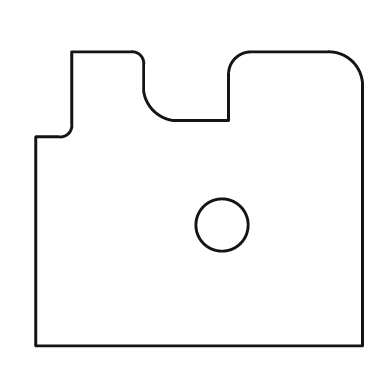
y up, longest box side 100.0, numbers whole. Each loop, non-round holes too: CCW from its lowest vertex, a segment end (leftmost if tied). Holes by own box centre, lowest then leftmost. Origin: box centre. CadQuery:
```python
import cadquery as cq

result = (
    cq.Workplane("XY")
    .moveTo(-50.0, -45.0)
    .lineTo(50.0, -45.0)
    .lineTo(50.0, 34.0)
    .threePointArc((47.0, 42.0), (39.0, 45.0))
    .lineTo(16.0, 45.0)
    .threePointArc((11.0, 43.0), (9.0, 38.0))
    .lineTo(9.0, 24.0)
    .lineTo(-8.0, 24.0)
    .threePointArc((-14.0, 27.0), (-17.0, 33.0))
    .lineTo(-17.0, 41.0)
    .threePointArc((-18.0, 44.0), (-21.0, 45.0))
    .lineTo(-39.0, 45.0)
    .lineTo(-39.0, 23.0)
    .threePointArc((-40.0, 20.0), (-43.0, 19.0))
    .lineTo(-50.0, 19.0)
    .close()
    .moveTo(7.0, -8.0)
    .circle(8.0)
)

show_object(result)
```